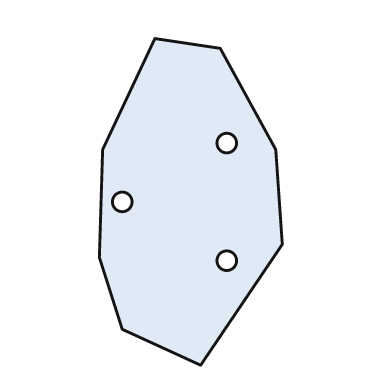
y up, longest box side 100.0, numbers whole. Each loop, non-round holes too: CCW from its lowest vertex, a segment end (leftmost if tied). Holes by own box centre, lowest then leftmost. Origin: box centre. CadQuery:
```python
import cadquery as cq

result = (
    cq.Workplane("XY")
    .moveTo(3.0, -50.0)
    .lineTo(28.0, -13.0)
    .lineTo(26.0, 16.0)
    .lineTo(9.0, 47.0)
    .lineTo(-11.0, 50.0)
    .lineTo(-27.0, 16.0)
    .lineTo(-28.0, -17.0)
    .lineTo(-21.0, -39.0)
    .close()
    .moveTo(11.0, -18.0)
    .circle(3.0)
    .moveTo(-21.0, 0.0)
    .circle(3.0)
    .moveTo(11.0, 18.0)
    .circle(3.0)
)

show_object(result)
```